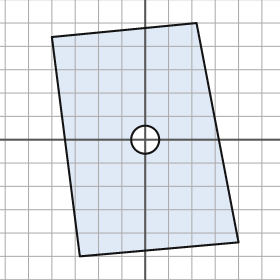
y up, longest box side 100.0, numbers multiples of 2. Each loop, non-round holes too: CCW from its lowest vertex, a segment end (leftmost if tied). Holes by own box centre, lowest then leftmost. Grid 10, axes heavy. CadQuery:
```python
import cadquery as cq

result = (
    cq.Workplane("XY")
    .moveTo(-28.0, -50.0)
    .lineTo(40.0, -44.0)
    .lineTo(22.0, 50.0)
    .lineTo(-40.0, 44.0)
    .close()
    .moveTo(0.0, 0.0)
    .circle(6.0)
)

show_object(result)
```